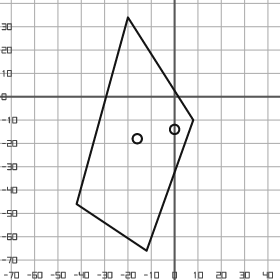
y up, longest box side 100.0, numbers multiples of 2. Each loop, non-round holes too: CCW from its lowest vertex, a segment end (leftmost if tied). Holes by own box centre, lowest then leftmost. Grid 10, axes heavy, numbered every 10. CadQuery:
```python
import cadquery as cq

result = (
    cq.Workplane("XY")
    .moveTo(-12.0, -66.0)
    .lineTo(8.0, -10.0)
    .lineTo(-20.0, 34.0)
    .lineTo(-42.0, -46.0)
    .close()
    .moveTo(-16.0, -18.0)
    .circle(2.0)
    .moveTo(0.0, -14.0)
    .circle(2.0)
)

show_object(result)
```